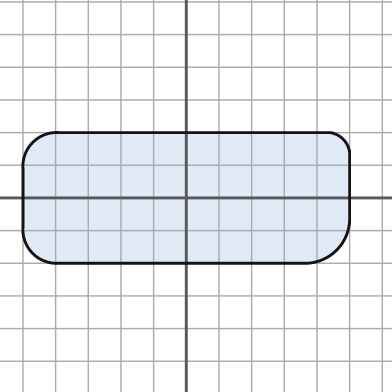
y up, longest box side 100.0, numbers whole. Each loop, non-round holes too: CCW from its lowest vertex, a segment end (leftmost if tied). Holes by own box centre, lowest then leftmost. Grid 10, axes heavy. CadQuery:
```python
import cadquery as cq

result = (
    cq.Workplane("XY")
    .moveTo(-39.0, -20.0)
    .lineTo(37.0, -20.0)
    .threePointArc((46.0, -16.0), (50.0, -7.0))
    .lineTo(50.0, 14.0)
    .threePointArc((48.0, 18.0), (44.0, 20.0))
    .lineTo(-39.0, 20.0)
    .threePointArc((-47.0, 17.0), (-50.0, 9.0))
    .lineTo(-50.0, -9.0)
    .threePointArc((-47.0, -17.0), (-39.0, -20.0))
    .close()
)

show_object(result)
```